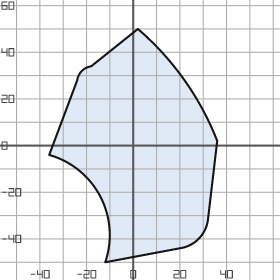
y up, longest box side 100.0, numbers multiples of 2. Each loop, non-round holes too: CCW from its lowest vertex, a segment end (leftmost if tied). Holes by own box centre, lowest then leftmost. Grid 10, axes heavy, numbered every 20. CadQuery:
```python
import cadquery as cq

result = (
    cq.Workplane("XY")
    .moveTo(-12.0, -50.0)
    .lineTo(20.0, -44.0)
    .threePointArc((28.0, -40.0), (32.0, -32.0))
    .lineTo(36.0, 2.0)
    .threePointArc((22.0, 28.0), (2.0, 50.0))
    .lineTo(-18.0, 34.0)
    .threePointArc((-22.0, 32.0), (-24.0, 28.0))
    .lineTo(-36.0, -4.0)
    .threePointArc((-14.0, -22.0), (-12.0, -50.0))
    .close()
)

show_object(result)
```